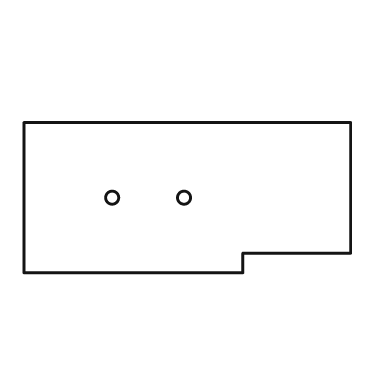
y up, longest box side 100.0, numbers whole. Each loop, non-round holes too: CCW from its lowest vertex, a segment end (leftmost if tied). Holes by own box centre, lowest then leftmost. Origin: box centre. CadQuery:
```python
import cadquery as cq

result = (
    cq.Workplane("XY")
    .moveTo(-50.0, -23.0)
    .lineTo(17.0, -23.0)
    .lineTo(17.0, -17.0)
    .lineTo(50.0, -17.0)
    .lineTo(50.0, 23.0)
    .lineTo(-50.0, 23.0)
    .close()
    .moveTo(-23.0, 0.0)
    .circle(2.0)
    .moveTo(-1.0, 0.0)
    .circle(2.0)
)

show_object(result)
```